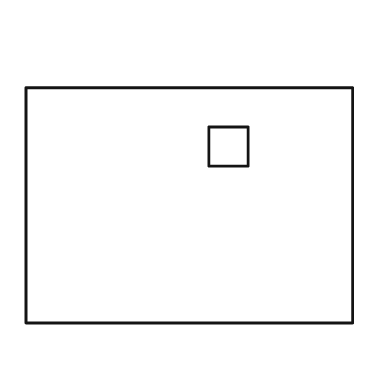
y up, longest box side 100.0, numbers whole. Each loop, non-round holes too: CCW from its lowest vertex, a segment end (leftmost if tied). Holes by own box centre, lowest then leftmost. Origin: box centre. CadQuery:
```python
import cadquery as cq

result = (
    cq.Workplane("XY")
    .moveTo(-50.0, -36.0)
    .lineTo(50.0, -36.0)
    .lineTo(50.0, 36.0)
    .lineTo(-50.0, 36.0)
    .close()
    .moveTo(6.0, 12.0)
    .lineTo(18.0, 12.0)
    .lineTo(18.0, 24.0)
    .lineTo(6.0, 24.0)
    .close()
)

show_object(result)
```